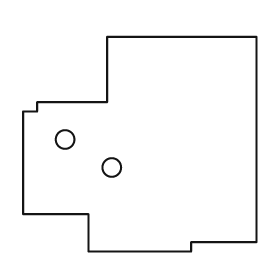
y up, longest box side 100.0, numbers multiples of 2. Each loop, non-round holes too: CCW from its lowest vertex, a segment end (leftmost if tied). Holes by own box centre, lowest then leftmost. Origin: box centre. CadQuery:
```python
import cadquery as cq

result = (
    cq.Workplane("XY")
    .moveTo(-22.0, -46.0)
    .lineTo(22.0, -46.0)
    .lineTo(22.0, -42.0)
    .lineTo(50.0, -42.0)
    .lineTo(50.0, 46.0)
    .lineTo(-14.0, 46.0)
    .lineTo(-14.0, 18.0)
    .lineTo(-44.0, 18.0)
    .lineTo(-44.0, 14.0)
    .lineTo(-50.0, 14.0)
    .lineTo(-50.0, -30.0)
    .lineTo(-22.0, -30.0)
    .close()
    .moveTo(-12.0, -10.0)
    .circle(4.0)
    .moveTo(-32.0, 2.0)
    .circle(4.0)
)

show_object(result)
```